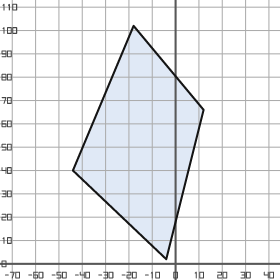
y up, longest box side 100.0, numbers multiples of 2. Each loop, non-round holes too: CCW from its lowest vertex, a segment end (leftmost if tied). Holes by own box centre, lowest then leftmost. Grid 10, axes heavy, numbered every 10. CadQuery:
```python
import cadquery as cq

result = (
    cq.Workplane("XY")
    .moveTo(-4.0, 2.0)
    .lineTo(12.0, 66.0)
    .lineTo(-18.0, 102.0)
    .lineTo(-44.0, 40.0)
    .close()
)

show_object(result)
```